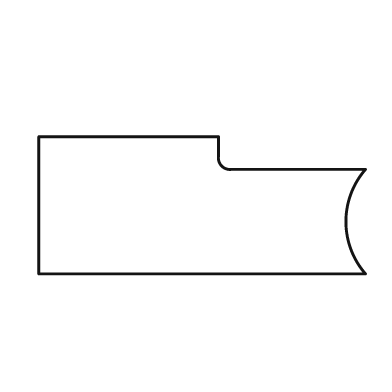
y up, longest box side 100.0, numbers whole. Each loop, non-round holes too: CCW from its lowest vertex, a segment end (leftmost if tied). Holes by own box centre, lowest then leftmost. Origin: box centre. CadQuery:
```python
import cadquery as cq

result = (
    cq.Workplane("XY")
    .moveTo(-50.0, -21.0)
    .lineTo(50.0, -21.0)
    .threePointArc((44.0, -5.0), (50.0, 11.0))
    .lineTo(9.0, 11.0)
    .threePointArc((6.0, 12.0), (5.0, 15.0))
    .lineTo(5.0, 21.0)
    .lineTo(-50.0, 21.0)
    .close()
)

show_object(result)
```